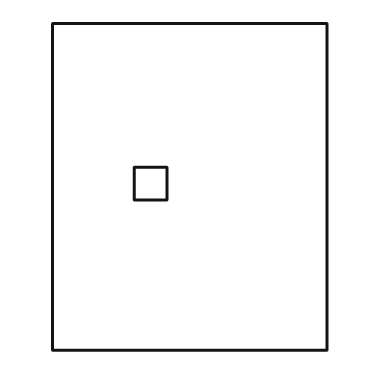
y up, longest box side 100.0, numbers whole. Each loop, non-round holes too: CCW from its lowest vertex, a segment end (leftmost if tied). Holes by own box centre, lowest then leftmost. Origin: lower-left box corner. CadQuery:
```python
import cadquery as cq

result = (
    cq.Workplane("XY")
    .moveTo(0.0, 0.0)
    .lineTo(84.0, 0.0)
    .lineTo(84.0, 100.0)
    .lineTo(0.0, 100.0)
    .close()
    .moveTo(25.0, 46.0)
    .lineTo(35.0, 46.0)
    .lineTo(35.0, 56.0)
    .lineTo(25.0, 56.0)
    .close()
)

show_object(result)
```